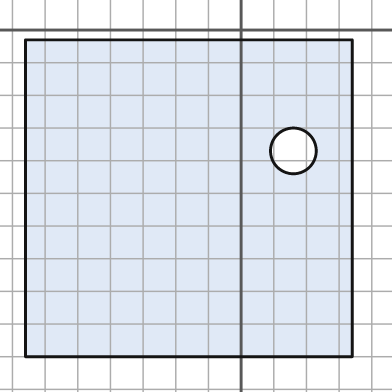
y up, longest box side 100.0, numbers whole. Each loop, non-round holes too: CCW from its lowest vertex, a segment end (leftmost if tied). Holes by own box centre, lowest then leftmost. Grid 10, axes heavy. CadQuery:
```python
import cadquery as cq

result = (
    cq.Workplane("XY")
    .moveTo(-66.0, -100.0)
    .lineTo(34.0, -100.0)
    .lineTo(34.0, -3.0)
    .lineTo(-66.0, -3.0)
    .close()
    .moveTo(16.0, -37.0)
    .circle(7.0)
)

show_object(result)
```